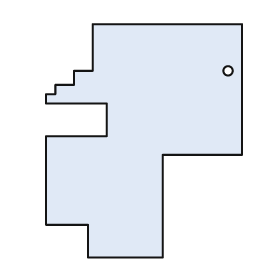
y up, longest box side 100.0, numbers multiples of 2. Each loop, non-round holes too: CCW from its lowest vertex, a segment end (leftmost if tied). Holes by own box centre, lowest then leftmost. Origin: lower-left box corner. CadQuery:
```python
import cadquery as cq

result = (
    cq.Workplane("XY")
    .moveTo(18.0, 0.0)
    .lineTo(50.0, 0.0)
    .lineTo(50.0, 44.0)
    .lineTo(84.0, 44.0)
    .lineTo(84.0, 100.0)
    .lineTo(20.0, 100.0)
    .lineTo(20.0, 80.0)
    .lineTo(12.0, 80.0)
    .lineTo(12.0, 74.0)
    .lineTo(4.0, 74.0)
    .lineTo(4.0, 70.0)
    .lineTo(0.0, 70.0)
    .lineTo(0.0, 66.0)
    .lineTo(26.0, 66.0)
    .lineTo(26.0, 52.0)
    .lineTo(0.0, 52.0)
    .lineTo(0.0, 14.0)
    .lineTo(18.0, 14.0)
    .close()
    .moveTo(78.0, 80.0)
    .circle(2.0)
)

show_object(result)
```